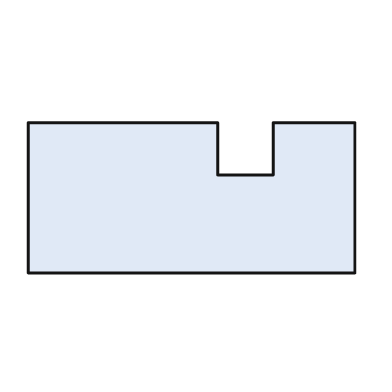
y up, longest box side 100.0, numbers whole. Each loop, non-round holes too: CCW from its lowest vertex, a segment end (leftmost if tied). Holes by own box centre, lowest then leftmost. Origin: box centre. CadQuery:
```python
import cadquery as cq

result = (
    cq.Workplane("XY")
    .moveTo(-50.0, -23.0)
    .lineTo(50.0, -23.0)
    .lineTo(50.0, 23.0)
    .lineTo(25.0, 23.0)
    .lineTo(25.0, 7.0)
    .lineTo(8.0, 7.0)
    .lineTo(8.0, 23.0)
    .lineTo(-50.0, 23.0)
    .close()
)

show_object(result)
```